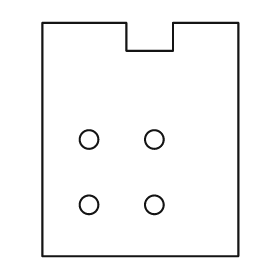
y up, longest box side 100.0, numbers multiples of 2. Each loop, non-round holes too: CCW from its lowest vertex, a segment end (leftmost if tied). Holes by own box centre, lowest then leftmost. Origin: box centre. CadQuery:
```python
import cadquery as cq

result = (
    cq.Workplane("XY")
    .moveTo(-42.0, -50.0)
    .lineTo(42.0, -50.0)
    .lineTo(42.0, 50.0)
    .lineTo(14.0, 50.0)
    .lineTo(14.0, 38.0)
    .lineTo(-6.0, 38.0)
    .lineTo(-6.0, 50.0)
    .lineTo(-42.0, 50.0)
    .close()
    .moveTo(-22.0, -28.0)
    .circle(4.0)
    .moveTo(6.0, -28.0)
    .circle(4.0)
    .moveTo(-22.0, 0.0)
    .circle(4.0)
    .moveTo(6.0, 0.0)
    .circle(4.0)
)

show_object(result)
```